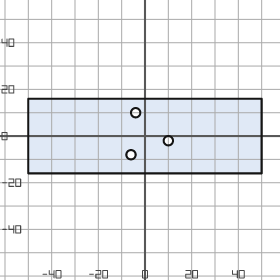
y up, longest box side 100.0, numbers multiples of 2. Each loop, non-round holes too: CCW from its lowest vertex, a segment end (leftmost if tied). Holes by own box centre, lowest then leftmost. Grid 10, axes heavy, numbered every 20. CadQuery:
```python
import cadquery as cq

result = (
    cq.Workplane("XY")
    .moveTo(-50.0, -16.0)
    .lineTo(50.0, -16.0)
    .lineTo(50.0, 16.0)
    .lineTo(-50.0, 16.0)
    .close()
    .moveTo(-6.0, -8.0)
    .circle(2.0)
    .moveTo(10.0, -2.0)
    .circle(2.0)
    .moveTo(-4.0, 10.0)
    .circle(2.0)
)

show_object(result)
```